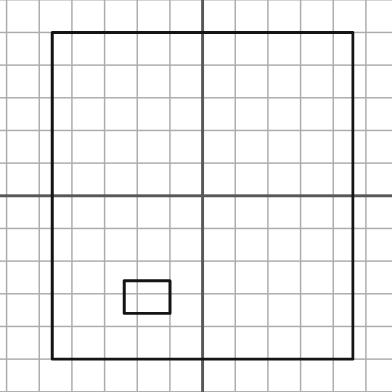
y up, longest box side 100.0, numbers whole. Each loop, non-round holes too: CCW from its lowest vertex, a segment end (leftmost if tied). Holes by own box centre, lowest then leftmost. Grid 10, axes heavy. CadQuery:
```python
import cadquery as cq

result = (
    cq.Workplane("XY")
    .moveTo(-46.0, -50.0)
    .lineTo(46.0, -50.0)
    .lineTo(46.0, 50.0)
    .lineTo(-46.0, 50.0)
    .close()
    .moveTo(-24.0, -36.0)
    .lineTo(-10.0, -36.0)
    .lineTo(-10.0, -26.0)
    .lineTo(-24.0, -26.0)
    .close()
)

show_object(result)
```